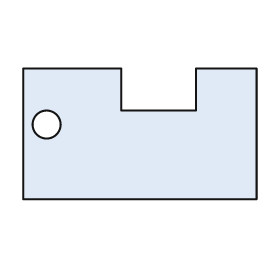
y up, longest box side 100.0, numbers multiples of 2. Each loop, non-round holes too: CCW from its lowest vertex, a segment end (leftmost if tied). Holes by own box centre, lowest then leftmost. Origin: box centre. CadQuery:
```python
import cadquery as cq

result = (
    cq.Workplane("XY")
    .moveTo(-50.0, -28.0)
    .lineTo(50.0, -28.0)
    .lineTo(50.0, 28.0)
    .lineTo(24.0, 28.0)
    .lineTo(24.0, 10.0)
    .lineTo(-8.0, 10.0)
    .lineTo(-8.0, 28.0)
    .lineTo(-50.0, 28.0)
    .close()
    .moveTo(-40.0, 4.0)
    .circle(6.0)
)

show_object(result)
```